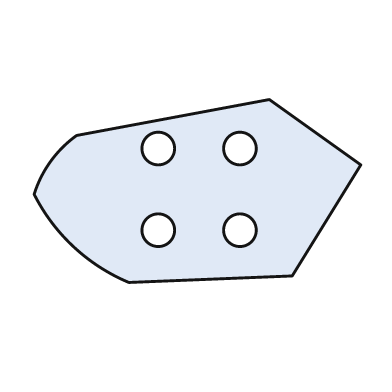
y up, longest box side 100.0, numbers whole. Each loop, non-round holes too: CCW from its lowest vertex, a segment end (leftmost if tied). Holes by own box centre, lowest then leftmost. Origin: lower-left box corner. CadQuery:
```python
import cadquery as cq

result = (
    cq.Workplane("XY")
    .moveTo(29.0, 0.0)
    .lineTo(79.0, 2.0)
    .lineTo(100.0, 36.0)
    .lineTo(72.0, 56.0)
    .lineTo(13.0, 45.0)
    .threePointArc((5.0, 37.0), (0.0, 27.0))
    .threePointArc((12.0, 11.0), (29.0, 0.0))
    .close()
    .moveTo(38.0, 16.0)
    .circle(5.0)
    .moveTo(63.0, 16.0)
    .circle(5.0)
    .moveTo(38.0, 41.0)
    .circle(5.0)
    .moveTo(63.0, 41.0)
    .circle(5.0)
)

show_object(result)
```